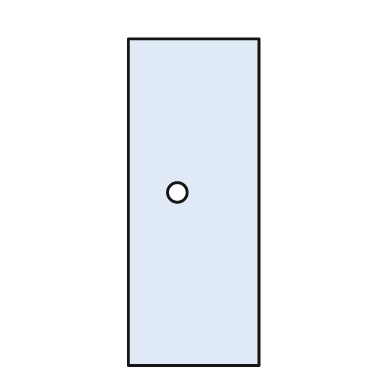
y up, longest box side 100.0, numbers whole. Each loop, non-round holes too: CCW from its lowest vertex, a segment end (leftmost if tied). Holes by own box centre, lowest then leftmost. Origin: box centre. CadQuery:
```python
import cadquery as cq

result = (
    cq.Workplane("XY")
    .moveTo(-20.0, -50.0)
    .lineTo(20.0, -50.0)
    .lineTo(20.0, 50.0)
    .lineTo(-20.0, 50.0)
    .close()
    .moveTo(-5.0, 3.0)
    .circle(3.0)
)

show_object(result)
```